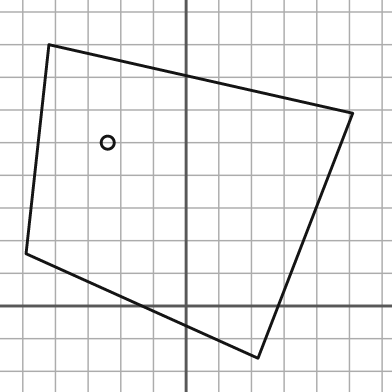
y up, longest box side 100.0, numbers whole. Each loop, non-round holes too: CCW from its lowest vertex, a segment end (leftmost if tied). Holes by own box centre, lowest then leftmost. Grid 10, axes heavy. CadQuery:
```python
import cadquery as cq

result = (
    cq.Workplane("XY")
    .moveTo(22.0, -16.0)
    .lineTo(51.0, 59.0)
    .lineTo(-42.0, 80.0)
    .lineTo(-49.0, 16.0)
    .close()
    .moveTo(-24.0, 50.0)
    .circle(2.0)
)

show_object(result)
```